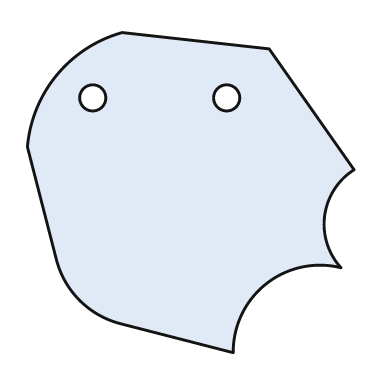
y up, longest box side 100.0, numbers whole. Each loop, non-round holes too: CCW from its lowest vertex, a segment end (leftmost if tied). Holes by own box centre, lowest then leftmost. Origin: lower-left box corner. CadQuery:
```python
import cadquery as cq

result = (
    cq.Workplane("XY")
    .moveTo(63.0, 0.0)
    .threePointArc((73.0, 21.0), (96.0, 26.0))
    .threePointArc((91.0, 42.0), (100.0, 56.0))
    .lineTo(74.0, 93.0)
    .lineTo(29.0, 98.0)
    .threePointArc((9.0, 85.0), (0.0, 63.0))
    .lineTo(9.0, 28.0)
    .threePointArc((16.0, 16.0), (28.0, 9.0))
    .close()
    .moveTo(20.0, 78.0)
    .circle(4.0)
    .moveTo(61.0, 78.0)
    .circle(4.0)
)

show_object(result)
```